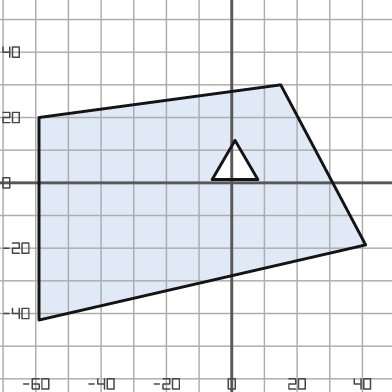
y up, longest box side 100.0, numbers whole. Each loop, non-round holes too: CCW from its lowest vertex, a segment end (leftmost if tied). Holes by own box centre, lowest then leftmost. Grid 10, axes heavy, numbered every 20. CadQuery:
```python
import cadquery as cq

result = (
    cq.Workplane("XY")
    .moveTo(-59.0, -42.0)
    .lineTo(41.0, -19.0)
    .lineTo(15.0, 30.0)
    .lineTo(-59.0, 20.0)
    .close()
    .moveTo(-6.0, 1.0)
    .lineTo(8.0, 1.0)
    .lineTo(1.0, 13.0)
    .close()
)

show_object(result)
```